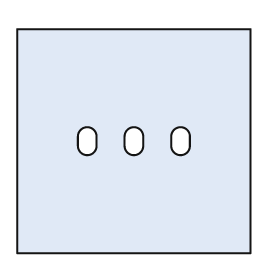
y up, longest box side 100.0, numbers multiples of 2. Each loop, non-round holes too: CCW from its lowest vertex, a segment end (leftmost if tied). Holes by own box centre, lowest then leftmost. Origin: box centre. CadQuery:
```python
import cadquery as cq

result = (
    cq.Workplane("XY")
    .moveTo(-50.0, -48.0)
    .lineTo(50.0, -48.0)
    .lineTo(50.0, 48.0)
    .lineTo(-50.0, 48.0)
    .close()
    .moveTo(-24.0, -2.0)
    .threePointArc((-20.0, -6.0), (-16.0, -2.0))
    .lineTo(-16.0, 2.0)
    .threePointArc((-20.0, 6.0), (-24.0, 2.0))
    .close()
    .moveTo(-4.0, -2.0)
    .threePointArc((0.0, -6.0), (4.0, -2.0))
    .lineTo(4.0, 2.0)
    .threePointArc((0.0, 6.0), (-4.0, 2.0))
    .close()
    .moveTo(16.0, -2.0)
    .threePointArc((20.0, -6.0), (24.0, -2.0))
    .lineTo(24.0, 2.0)
    .threePointArc((20.0, 6.0), (16.0, 2.0))
    .close()
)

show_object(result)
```